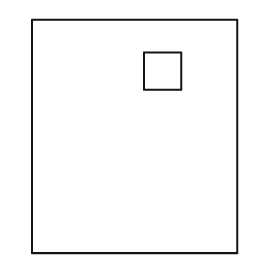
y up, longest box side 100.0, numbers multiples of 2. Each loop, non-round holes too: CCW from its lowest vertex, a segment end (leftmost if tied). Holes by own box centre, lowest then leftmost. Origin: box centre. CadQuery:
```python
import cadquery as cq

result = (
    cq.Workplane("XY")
    .moveTo(-44.0, -50.0)
    .lineTo(44.0, -50.0)
    .lineTo(44.0, 50.0)
    .lineTo(-44.0, 50.0)
    .close()
    .moveTo(4.0, 20.0)
    .lineTo(20.0, 20.0)
    .lineTo(20.0, 36.0)
    .lineTo(4.0, 36.0)
    .close()
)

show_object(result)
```